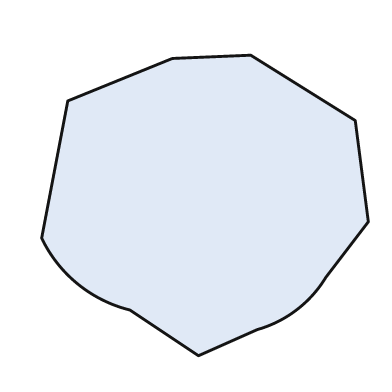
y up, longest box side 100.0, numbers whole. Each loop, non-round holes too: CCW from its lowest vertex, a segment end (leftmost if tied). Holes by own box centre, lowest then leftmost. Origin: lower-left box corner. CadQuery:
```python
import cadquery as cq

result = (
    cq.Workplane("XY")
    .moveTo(48.0, 0.0)
    .lineTo(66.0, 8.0)
    .threePointArc((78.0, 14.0), (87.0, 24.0))
    .lineTo(100.0, 41.0)
    .lineTo(96.0, 72.0)
    .lineTo(64.0, 92.0)
    .lineTo(40.0, 91.0)
    .lineTo(8.0, 78.0)
    .lineTo(0.0, 36.0)
    .threePointArc((11.0, 22.0), (27.0, 14.0))
    .close()
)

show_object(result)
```